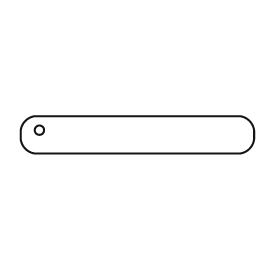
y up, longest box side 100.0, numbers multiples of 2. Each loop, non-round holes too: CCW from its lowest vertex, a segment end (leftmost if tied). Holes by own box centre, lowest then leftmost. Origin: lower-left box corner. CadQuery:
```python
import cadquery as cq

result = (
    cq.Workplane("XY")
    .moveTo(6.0, 0.0)
    .lineTo(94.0, 0.0)
    .threePointArc((98.0, 2.0), (100.0, 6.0))
    .lineTo(100.0, 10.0)
    .threePointArc((98.0, 14.0), (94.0, 16.0))
    .lineTo(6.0, 16.0)
    .threePointArc((2.0, 14.0), (0.0, 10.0))
    .lineTo(0.0, 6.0)
    .threePointArc((2.0, 2.0), (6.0, 0.0))
    .close()
    .moveTo(8.0, 10.0)
    .circle(2.0)
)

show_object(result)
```